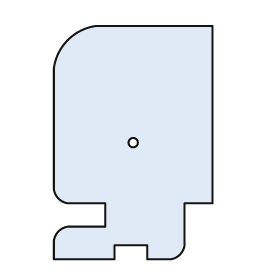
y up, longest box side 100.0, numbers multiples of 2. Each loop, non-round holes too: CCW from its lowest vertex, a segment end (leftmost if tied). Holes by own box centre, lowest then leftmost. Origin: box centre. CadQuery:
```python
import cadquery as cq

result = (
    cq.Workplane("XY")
    .moveTo(-34.0, -50.0)
    .lineTo(-8.0, -50.0)
    .lineTo(-8.0, -44.0)
    .lineTo(6.0, -44.0)
    .lineTo(6.0, -50.0)
    .lineTo(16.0, -50.0)
    .threePointArc((20.0, -48.0), (22.0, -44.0))
    .lineTo(22.0, -26.0)
    .lineTo(34.0, -26.0)
    .lineTo(34.0, 50.0)
    .lineTo(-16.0, 50.0)
    .threePointArc((-28.0, 44.0), (-34.0, 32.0))
    .lineTo(-34.0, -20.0)
    .threePointArc((-32.0, -24.0), (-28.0, -26.0))
    .lineTo(-12.0, -26.0)
    .lineTo(-12.0, -36.0)
    .lineTo(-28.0, -36.0)
    .threePointArc((-32.0, -38.0), (-34.0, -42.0))
    .close()
    .moveTo(0.0, 0.0)
    .circle(2.0)
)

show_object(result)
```